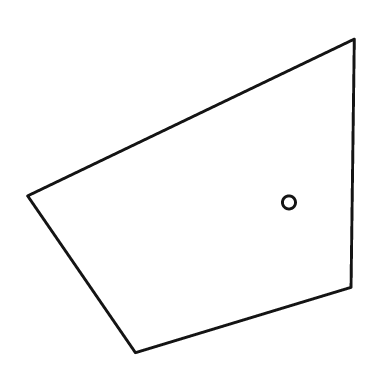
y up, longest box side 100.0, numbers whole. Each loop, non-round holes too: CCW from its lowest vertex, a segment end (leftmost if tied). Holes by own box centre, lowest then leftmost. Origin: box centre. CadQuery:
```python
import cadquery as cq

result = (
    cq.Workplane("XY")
    .moveTo(-17.0, -48.0)
    .lineTo(49.0, -28.0)
    .lineTo(50.0, 48.0)
    .lineTo(-50.0, 0.0)
    .close()
    .moveTo(30.0, -2.0)
    .circle(2.0)
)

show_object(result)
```